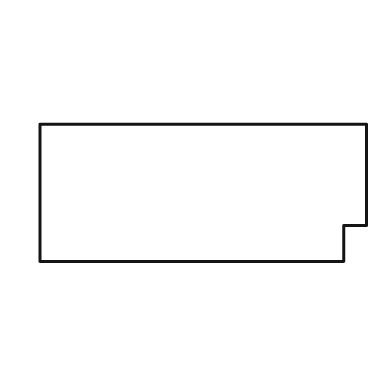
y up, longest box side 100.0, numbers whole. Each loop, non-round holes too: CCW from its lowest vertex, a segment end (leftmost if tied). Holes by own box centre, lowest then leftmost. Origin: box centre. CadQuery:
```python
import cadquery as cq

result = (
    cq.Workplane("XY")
    .moveTo(-50.0, -21.0)
    .lineTo(43.0, -21.0)
    .lineTo(43.0, -10.0)
    .lineTo(50.0, -10.0)
    .lineTo(50.0, 21.0)
    .lineTo(-50.0, 21.0)
    .close()
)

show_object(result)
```